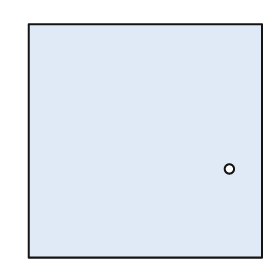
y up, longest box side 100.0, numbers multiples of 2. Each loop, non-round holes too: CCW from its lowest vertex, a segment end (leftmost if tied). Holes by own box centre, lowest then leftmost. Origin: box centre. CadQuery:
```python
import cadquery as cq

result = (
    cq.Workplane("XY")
    .moveTo(-50.0, -50.0)
    .lineTo(50.0, -50.0)
    .lineTo(50.0, 50.0)
    .lineTo(-50.0, 50.0)
    .close()
    .moveTo(36.0, -12.0)
    .circle(2.0)
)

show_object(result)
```